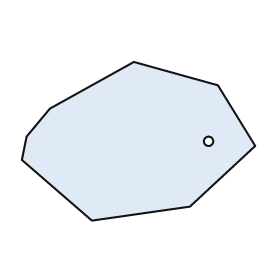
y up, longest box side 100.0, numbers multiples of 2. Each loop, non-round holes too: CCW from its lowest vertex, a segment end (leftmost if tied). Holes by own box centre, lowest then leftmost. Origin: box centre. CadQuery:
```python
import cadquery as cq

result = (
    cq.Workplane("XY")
    .moveTo(-20.0, -34.0)
    .lineTo(22.0, -28.0)
    .lineTo(50.0, -2.0)
    .lineTo(34.0, 24.0)
    .lineTo(-2.0, 34.0)
    .lineTo(-38.0, 14.0)
    .lineTo(-48.0, 2.0)
    .lineTo(-50.0, -8.0)
    .close()
    .moveTo(30.0, 0.0)
    .circle(2.0)
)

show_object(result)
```